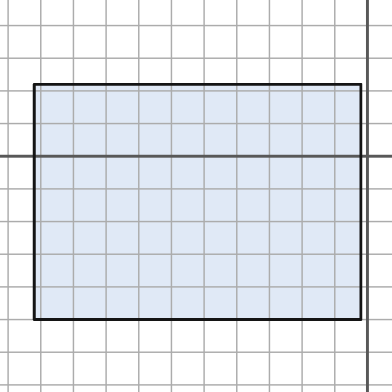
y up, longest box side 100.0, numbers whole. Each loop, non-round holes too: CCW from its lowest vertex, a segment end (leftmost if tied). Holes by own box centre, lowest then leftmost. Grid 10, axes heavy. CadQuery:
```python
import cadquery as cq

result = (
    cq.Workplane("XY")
    .moveTo(-102.0, -50.0)
    .lineTo(-2.0, -50.0)
    .lineTo(-2.0, 22.0)
    .lineTo(-102.0, 22.0)
    .close()
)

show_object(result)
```